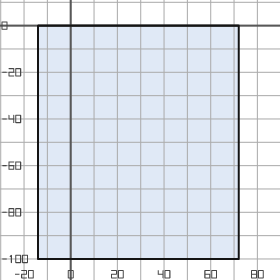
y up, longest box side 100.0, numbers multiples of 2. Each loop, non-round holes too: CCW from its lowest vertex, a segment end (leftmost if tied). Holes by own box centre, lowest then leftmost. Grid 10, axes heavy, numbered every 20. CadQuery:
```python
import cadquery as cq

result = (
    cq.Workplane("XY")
    .moveTo(-14.0, -100.0)
    .lineTo(72.0, -100.0)
    .lineTo(72.0, 0.0)
    .lineTo(-14.0, 0.0)
    .close()
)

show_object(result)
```